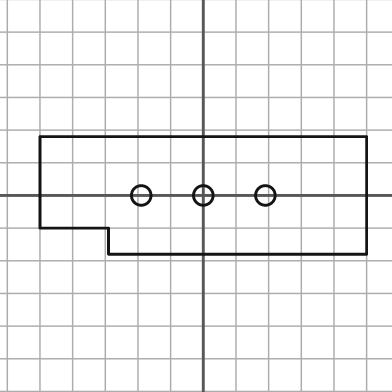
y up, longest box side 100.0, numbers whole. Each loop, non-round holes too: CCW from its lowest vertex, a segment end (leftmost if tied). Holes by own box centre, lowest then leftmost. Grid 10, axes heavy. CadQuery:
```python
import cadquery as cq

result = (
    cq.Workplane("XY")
    .moveTo(-29.0, -18.0)
    .lineTo(50.0, -18.0)
    .lineTo(50.0, 18.0)
    .lineTo(-50.0, 18.0)
    .lineTo(-50.0, -10.0)
    .lineTo(-29.0, -10.0)
    .close()
    .moveTo(-19.0, 0.0)
    .circle(3.0)
    .moveTo(0.0, 0.0)
    .circle(3.0)
    .moveTo(19.0, 0.0)
    .circle(3.0)
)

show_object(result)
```